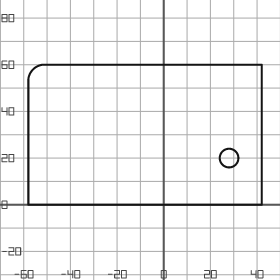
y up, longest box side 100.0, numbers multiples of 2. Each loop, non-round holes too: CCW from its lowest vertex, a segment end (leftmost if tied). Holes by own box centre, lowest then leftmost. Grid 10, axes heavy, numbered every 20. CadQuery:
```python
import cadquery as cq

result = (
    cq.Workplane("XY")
    .moveTo(-58.0, 0.0)
    .lineTo(42.0, 0.0)
    .lineTo(42.0, 60.0)
    .lineTo(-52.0, 60.0)
    .threePointArc((-56.0, 58.0), (-58.0, 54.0))
    .close()
    .moveTo(28.0, 20.0)
    .circle(4.0)
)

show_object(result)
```